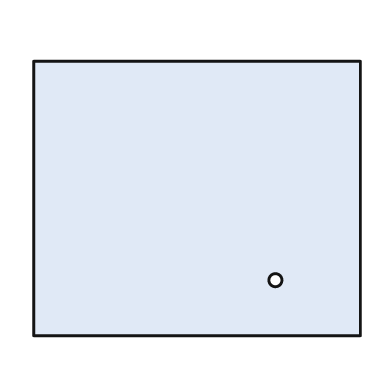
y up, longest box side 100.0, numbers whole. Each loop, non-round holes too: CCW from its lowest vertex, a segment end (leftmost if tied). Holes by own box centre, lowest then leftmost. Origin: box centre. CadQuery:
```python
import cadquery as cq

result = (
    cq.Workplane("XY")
    .moveTo(-50.0, -42.0)
    .lineTo(50.0, -42.0)
    .lineTo(50.0, 42.0)
    .lineTo(-50.0, 42.0)
    .close()
    .moveTo(24.0, -25.0)
    .circle(2.0)
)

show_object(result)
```